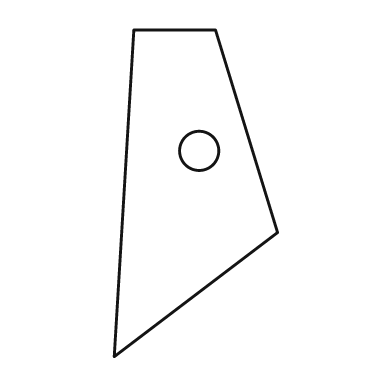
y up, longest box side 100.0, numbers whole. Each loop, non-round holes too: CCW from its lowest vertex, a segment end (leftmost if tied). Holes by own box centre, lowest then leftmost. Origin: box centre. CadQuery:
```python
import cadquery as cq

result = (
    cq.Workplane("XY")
    .moveTo(-25.0, -50.0)
    .lineTo(25.0, -12.0)
    .lineTo(6.0, 50.0)
    .lineTo(-19.0, 50.0)
    .close()
    .moveTo(1.0, 13.0)
    .circle(6.0)
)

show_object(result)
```